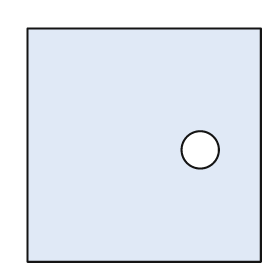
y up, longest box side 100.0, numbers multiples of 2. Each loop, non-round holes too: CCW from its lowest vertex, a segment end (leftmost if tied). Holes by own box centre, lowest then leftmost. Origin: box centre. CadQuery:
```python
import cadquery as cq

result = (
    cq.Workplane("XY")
    .moveTo(-50.0, -50.0)
    .lineTo(50.0, -50.0)
    .lineTo(50.0, 50.0)
    .lineTo(-50.0, 50.0)
    .close()
    .moveTo(24.0, -2.0)
    .circle(8.0)
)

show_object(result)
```